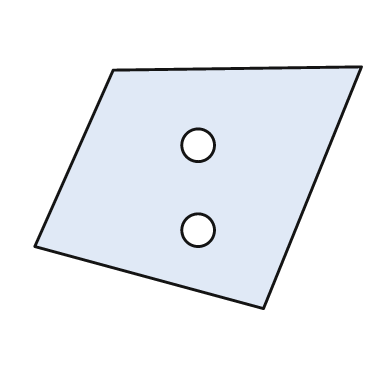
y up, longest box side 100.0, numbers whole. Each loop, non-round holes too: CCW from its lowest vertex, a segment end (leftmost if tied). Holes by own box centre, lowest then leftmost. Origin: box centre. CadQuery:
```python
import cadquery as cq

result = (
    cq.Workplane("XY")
    .moveTo(20.0, -37.0)
    .lineTo(50.0, 37.0)
    .lineTo(-26.0, 36.0)
    .lineTo(-50.0, -18.0)
    .close()
    .moveTo(0.0, -13.0)
    .circle(5.0)
    .moveTo(0.0, 13.0)
    .circle(5.0)
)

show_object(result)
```